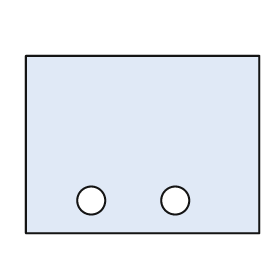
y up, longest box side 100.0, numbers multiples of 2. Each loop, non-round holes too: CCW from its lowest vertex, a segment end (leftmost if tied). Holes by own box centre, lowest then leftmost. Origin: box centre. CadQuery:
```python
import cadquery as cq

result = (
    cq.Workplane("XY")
    .moveTo(-50.0, -38.0)
    .lineTo(50.0, -38.0)
    .lineTo(50.0, 38.0)
    .lineTo(-50.0, 38.0)
    .close()
    .moveTo(-22.0, -24.0)
    .circle(6.0)
    .moveTo(14.0, -24.0)
    .circle(6.0)
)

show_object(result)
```